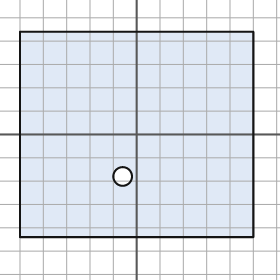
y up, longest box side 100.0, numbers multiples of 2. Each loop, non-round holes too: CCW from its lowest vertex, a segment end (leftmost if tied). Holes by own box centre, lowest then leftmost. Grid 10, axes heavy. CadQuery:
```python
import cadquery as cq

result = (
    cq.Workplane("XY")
    .moveTo(-50.0, -44.0)
    .lineTo(50.0, -44.0)
    .lineTo(50.0, 44.0)
    .lineTo(-50.0, 44.0)
    .close()
    .moveTo(-6.0, -18.0)
    .circle(4.0)
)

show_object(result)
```